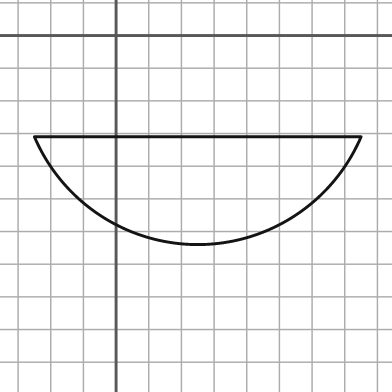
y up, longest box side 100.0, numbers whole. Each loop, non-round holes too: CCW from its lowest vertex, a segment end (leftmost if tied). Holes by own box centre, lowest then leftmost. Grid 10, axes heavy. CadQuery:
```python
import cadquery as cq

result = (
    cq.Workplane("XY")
    .moveTo(-25.0, -31.0)
    .threePointArc((25.0, -64.0), (75.0, -31.0))
    .close()
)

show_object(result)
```